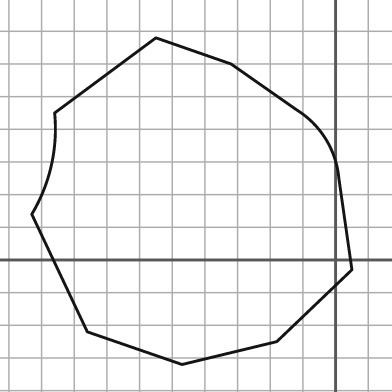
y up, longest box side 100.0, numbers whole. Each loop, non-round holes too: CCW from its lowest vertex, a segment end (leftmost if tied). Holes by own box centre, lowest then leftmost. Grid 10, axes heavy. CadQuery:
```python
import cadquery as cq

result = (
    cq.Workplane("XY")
    .moveTo(-47.0, -32.0)
    .lineTo(-18.0, -25.0)
    .lineTo(5.0, -3.0)
    .lineTo(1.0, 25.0)
    .threePointArc((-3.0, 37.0), (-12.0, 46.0))
    .lineTo(-32.0, 60.0)
    .lineTo(-55.0, 68.0)
    .lineTo(-86.0, 45.0)
    .threePointArc((-87.0, 29.0), (-93.0, 14.0))
    .lineTo(-76.0, -22.0)
    .close()
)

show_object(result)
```